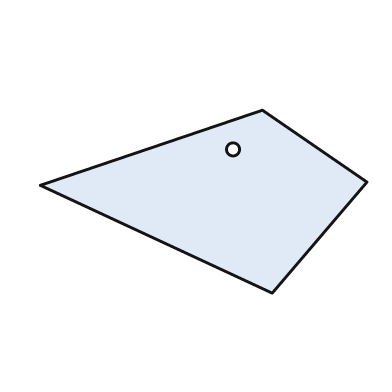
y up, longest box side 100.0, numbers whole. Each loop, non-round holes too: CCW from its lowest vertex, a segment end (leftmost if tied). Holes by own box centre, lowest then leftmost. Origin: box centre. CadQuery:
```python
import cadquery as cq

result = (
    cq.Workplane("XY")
    .moveTo(21.0, -28.0)
    .lineTo(50.0, 6.0)
    .lineTo(18.0, 28.0)
    .lineTo(-50.0, 5.0)
    .close()
    .moveTo(9.0, 16.0)
    .circle(2.0)
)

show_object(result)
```